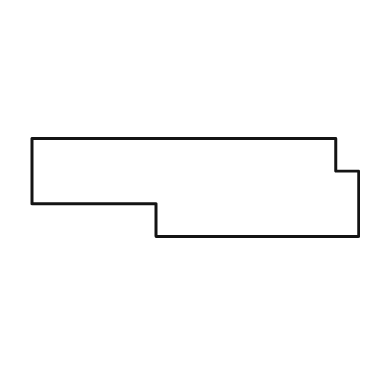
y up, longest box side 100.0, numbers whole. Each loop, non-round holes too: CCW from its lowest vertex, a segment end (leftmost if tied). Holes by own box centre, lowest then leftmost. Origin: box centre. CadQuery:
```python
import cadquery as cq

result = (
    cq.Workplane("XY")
    .moveTo(-12.0, -15.0)
    .lineTo(50.0, -15.0)
    .lineTo(50.0, 5.0)
    .lineTo(43.0, 5.0)
    .lineTo(43.0, 15.0)
    .lineTo(-50.0, 15.0)
    .lineTo(-50.0, -5.0)
    .lineTo(-12.0, -5.0)
    .close()
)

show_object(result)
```